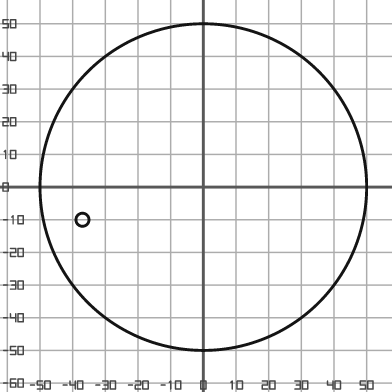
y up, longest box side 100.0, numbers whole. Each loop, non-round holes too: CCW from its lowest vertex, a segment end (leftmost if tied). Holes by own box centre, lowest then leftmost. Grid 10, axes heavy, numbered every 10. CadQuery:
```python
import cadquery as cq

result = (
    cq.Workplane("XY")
    .moveTo(0.0, 0.0)
    .circle(50.0)
    .moveTo(-37.0, -10.0)
    .circle(2.0)
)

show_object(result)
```